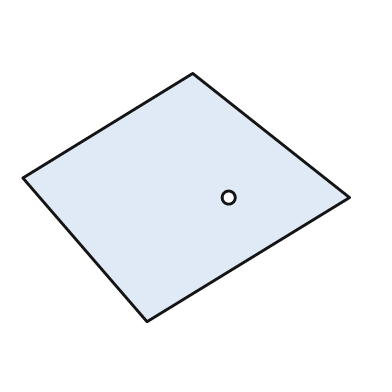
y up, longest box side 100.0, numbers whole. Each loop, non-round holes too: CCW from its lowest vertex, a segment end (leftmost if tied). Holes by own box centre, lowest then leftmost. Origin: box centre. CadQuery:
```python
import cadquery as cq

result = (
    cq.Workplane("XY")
    .moveTo(-12.0, -38.0)
    .lineTo(50.0, 0.0)
    .lineTo(2.0, 38.0)
    .lineTo(-50.0, 6.0)
    .close()
    .moveTo(13.0, 0.0)
    .circle(2.0)
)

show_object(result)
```